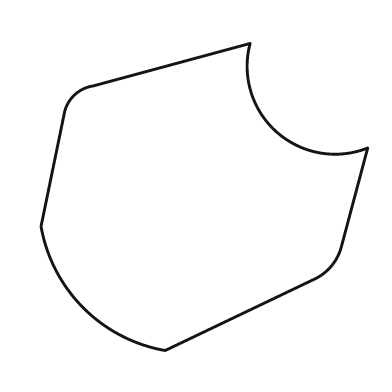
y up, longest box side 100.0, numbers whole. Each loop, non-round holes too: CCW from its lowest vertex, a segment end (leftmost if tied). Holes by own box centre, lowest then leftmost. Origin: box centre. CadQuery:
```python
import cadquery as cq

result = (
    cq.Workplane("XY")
    .moveTo(-12.0, -47.0)
    .lineTo(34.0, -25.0)
    .threePointArc((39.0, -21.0), (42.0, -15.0))
    .lineTo(50.0, 15.0)
    .threePointArc((22.0, 20.0), (14.0, 47.0))
    .lineTo(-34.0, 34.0)
    .threePointArc((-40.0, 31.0), (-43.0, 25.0))
    .lineTo(-50.0, -9.0)
    .threePointArc((-37.0, -34.0), (-12.0, -47.0))
    .close()
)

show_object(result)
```